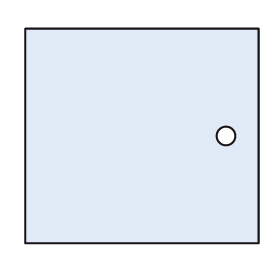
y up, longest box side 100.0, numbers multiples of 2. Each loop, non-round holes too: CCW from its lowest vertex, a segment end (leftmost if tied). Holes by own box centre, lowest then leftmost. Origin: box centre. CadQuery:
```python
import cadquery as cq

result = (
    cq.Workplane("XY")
    .moveTo(-50.0, -46.0)
    .lineTo(50.0, -46.0)
    .lineTo(50.0, 46.0)
    .lineTo(-50.0, 46.0)
    .close()
    .moveTo(36.0, 0.0)
    .circle(4.0)
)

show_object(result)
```